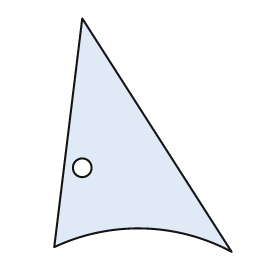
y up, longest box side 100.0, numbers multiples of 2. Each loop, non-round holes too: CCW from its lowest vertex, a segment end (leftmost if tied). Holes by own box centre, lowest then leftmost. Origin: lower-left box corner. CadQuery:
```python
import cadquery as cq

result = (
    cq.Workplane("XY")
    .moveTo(76.0, 0.0)
    .lineTo(12.0, 100.0)
    .lineTo(0.0, 2.0)
    .threePointArc((38.0, 10.0), (76.0, 0.0))
    .close()
    .moveTo(12.0, 36.0)
    .circle(4.0)
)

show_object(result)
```